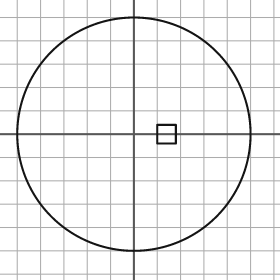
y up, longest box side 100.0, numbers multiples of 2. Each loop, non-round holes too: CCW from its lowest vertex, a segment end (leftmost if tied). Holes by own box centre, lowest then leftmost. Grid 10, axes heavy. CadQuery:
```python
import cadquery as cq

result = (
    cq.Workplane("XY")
    .moveTo(0.0, 0.0)
    .circle(50.0)
    .moveTo(10.0, -4.0)
    .lineTo(18.0, -4.0)
    .lineTo(18.0, 4.0)
    .lineTo(10.0, 4.0)
    .close()
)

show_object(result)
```